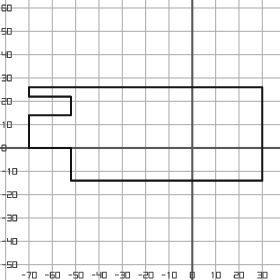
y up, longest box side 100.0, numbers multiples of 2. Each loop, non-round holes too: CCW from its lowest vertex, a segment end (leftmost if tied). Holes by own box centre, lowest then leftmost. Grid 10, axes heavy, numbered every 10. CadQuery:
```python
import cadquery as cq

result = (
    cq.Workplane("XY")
    .moveTo(-52.0, -14.0)
    .lineTo(30.0, -14.0)
    .lineTo(30.0, 26.0)
    .lineTo(-70.0, 26.0)
    .lineTo(-70.0, 22.0)
    .lineTo(-52.0, 22.0)
    .lineTo(-52.0, 14.0)
    .lineTo(-70.0, 14.0)
    .lineTo(-70.0, 0.0)
    .lineTo(-52.0, 0.0)
    .close()
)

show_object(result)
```